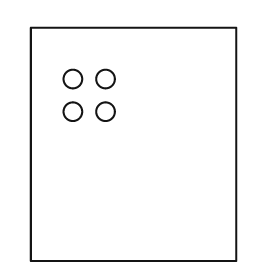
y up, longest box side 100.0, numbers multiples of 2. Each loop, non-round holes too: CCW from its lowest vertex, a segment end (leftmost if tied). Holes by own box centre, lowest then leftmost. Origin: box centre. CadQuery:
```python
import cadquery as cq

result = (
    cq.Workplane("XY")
    .moveTo(-44.0, -50.0)
    .lineTo(44.0, -50.0)
    .lineTo(44.0, 50.0)
    .lineTo(-44.0, 50.0)
    .close()
    .moveTo(-26.0, 14.0)
    .circle(4.0)
    .moveTo(-12.0, 14.0)
    .circle(4.0)
    .moveTo(-26.0, 28.0)
    .circle(4.0)
    .moveTo(-12.0, 28.0)
    .circle(4.0)
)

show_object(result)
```